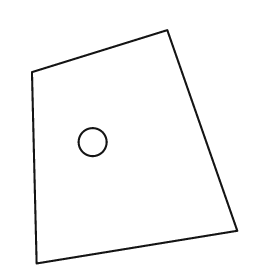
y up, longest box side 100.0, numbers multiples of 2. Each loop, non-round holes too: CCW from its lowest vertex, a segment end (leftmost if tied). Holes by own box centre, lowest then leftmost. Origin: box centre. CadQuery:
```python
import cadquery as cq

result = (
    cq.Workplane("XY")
    .moveTo(-42.0, -50.0)
    .lineTo(44.0, -36.0)
    .lineTo(14.0, 50.0)
    .lineTo(-44.0, 32.0)
    .close()
    .moveTo(-18.0, 2.0)
    .circle(6.0)
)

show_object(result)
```